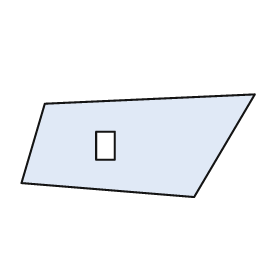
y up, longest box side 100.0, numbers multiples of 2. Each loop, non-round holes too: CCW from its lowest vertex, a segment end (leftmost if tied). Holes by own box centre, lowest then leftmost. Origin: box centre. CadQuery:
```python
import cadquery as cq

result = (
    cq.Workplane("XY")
    .moveTo(24.0, -22.0)
    .lineTo(50.0, 22.0)
    .lineTo(-40.0, 18.0)
    .lineTo(-50.0, -16.0)
    .close()
    .moveTo(-18.0, -6.0)
    .lineTo(-10.0, -6.0)
    .lineTo(-10.0, 6.0)
    .lineTo(-18.0, 6.0)
    .close()
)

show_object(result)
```